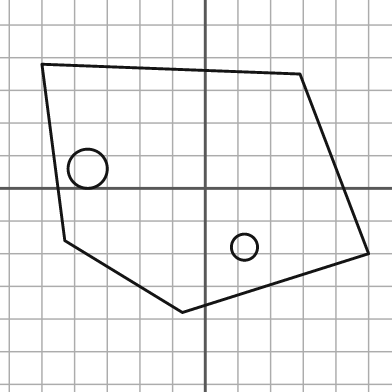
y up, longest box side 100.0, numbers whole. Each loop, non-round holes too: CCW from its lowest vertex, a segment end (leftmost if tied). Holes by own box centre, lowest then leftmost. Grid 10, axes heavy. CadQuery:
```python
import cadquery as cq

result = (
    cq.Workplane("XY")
    .moveTo(-7.0, -38.0)
    .lineTo(50.0, -20.0)
    .lineTo(29.0, 35.0)
    .lineTo(-50.0, 38.0)
    .lineTo(-43.0, -16.0)
    .close()
    .moveTo(12.0, -18.0)
    .circle(4.0)
    .moveTo(-36.0, 6.0)
    .circle(6.0)
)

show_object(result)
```